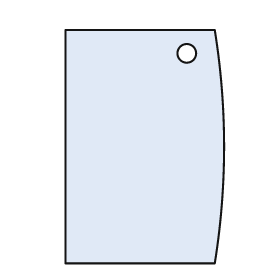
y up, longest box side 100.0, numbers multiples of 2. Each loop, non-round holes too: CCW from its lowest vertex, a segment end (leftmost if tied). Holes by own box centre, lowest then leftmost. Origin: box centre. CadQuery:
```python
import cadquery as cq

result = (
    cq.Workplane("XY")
    .moveTo(-34.0, -50.0)
    .lineTo(30.0, -50.0)
    .threePointArc((34.0, 0.0), (30.0, 50.0))
    .lineTo(-34.0, 50.0)
    .close()
    .moveTo(18.0, 40.0)
    .circle(4.0)
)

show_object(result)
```